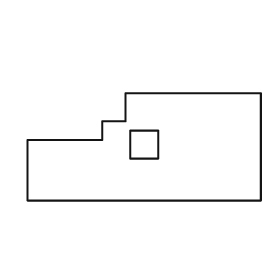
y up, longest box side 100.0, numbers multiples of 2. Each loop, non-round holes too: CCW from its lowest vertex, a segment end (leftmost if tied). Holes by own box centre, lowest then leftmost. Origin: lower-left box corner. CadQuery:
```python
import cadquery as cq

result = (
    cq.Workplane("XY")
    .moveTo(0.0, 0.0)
    .lineTo(100.0, 0.0)
    .lineTo(100.0, 46.0)
    .lineTo(42.0, 46.0)
    .lineTo(42.0, 34.0)
    .lineTo(32.0, 34.0)
    .lineTo(32.0, 26.0)
    .lineTo(0.0, 26.0)
    .close()
    .moveTo(44.0, 18.0)
    .lineTo(56.0, 18.0)
    .lineTo(56.0, 30.0)
    .lineTo(44.0, 30.0)
    .close()
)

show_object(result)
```